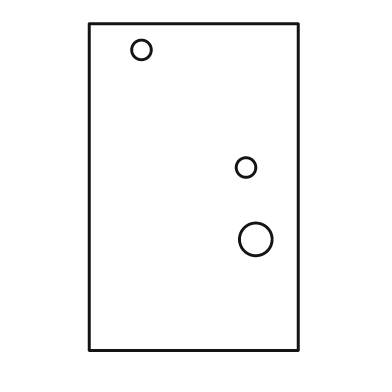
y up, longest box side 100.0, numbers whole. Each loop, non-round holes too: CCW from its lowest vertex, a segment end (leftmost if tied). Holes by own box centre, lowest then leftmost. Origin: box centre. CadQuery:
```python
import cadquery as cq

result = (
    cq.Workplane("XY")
    .moveTo(-32.0, -50.0)
    .lineTo(32.0, -50.0)
    .lineTo(32.0, 50.0)
    .lineTo(-32.0, 50.0)
    .close()
    .moveTo(19.0, -16.0)
    .circle(5.0)
    .moveTo(16.0, 6.0)
    .circle(3.0)
    .moveTo(-16.0, 42.0)
    .circle(3.0)
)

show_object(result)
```